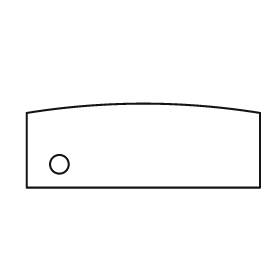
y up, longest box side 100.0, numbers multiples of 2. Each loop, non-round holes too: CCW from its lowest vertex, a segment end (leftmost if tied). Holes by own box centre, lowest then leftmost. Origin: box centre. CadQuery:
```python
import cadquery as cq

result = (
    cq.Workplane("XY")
    .moveTo(-50.0, -18.0)
    .lineTo(50.0, -18.0)
    .lineTo(50.0, 14.0)
    .threePointArc((0.0, 18.0), (-50.0, 14.0))
    .close()
    .moveTo(-36.0, -8.0)
    .circle(4.0)
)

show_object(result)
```